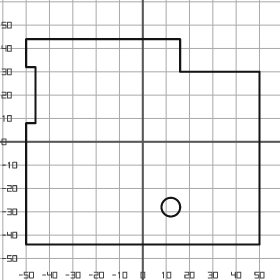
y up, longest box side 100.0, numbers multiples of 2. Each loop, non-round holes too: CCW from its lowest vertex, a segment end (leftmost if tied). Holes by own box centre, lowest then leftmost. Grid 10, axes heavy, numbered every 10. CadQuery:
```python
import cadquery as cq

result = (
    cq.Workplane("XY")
    .moveTo(-50.0, -44.0)
    .lineTo(50.0, -44.0)
    .lineTo(50.0, 30.0)
    .lineTo(16.0, 30.0)
    .lineTo(16.0, 44.0)
    .lineTo(-50.0, 44.0)
    .lineTo(-50.0, 32.0)
    .lineTo(-46.0, 32.0)
    .lineTo(-46.0, 8.0)
    .lineTo(-50.0, 8.0)
    .close()
    .moveTo(12.0, -28.0)
    .circle(4.0)
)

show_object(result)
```